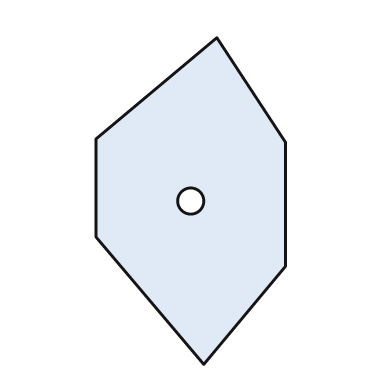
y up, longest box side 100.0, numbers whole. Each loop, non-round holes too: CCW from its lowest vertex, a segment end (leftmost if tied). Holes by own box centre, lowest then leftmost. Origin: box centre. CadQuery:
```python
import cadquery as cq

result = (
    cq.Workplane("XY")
    .moveTo(4.0, -50.0)
    .lineTo(29.0, -20.0)
    .lineTo(29.0, 18.0)
    .lineTo(8.0, 50.0)
    .lineTo(-29.0, 19.0)
    .lineTo(-29.0, -11.0)
    .close()
    .moveTo(0.0, 0.0)
    .circle(4.0)
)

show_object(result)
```